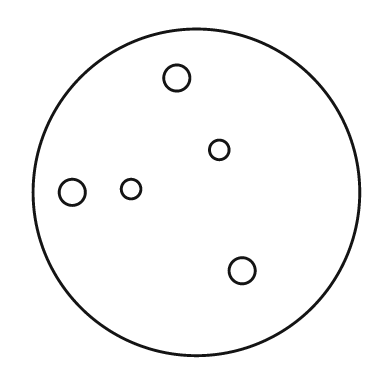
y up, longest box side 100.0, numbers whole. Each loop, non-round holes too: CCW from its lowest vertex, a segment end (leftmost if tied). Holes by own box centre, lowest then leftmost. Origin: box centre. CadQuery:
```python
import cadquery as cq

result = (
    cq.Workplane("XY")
    .moveTo(0.0, 0.0)
    .circle(50.0)
    .moveTo(14.0, -24.0)
    .circle(4.0)
    .moveTo(-38.0, 0.0)
    .circle(4.0)
    .moveTo(-20.0, 1.0)
    .circle(3.0)
    .moveTo(7.0, 13.0)
    .circle(3.0)
    .moveTo(-6.0, 35.0)
    .circle(4.0)
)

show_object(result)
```